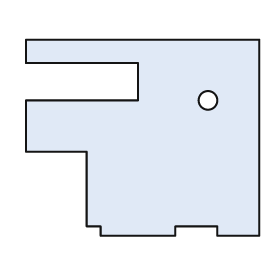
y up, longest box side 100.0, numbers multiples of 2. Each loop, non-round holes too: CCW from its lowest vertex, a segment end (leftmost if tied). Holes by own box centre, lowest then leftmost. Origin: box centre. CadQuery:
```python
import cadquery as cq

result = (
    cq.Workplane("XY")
    .moveTo(-18.0, -42.0)
    .lineTo(14.0, -42.0)
    .lineTo(14.0, -38.0)
    .lineTo(32.0, -38.0)
    .lineTo(32.0, -42.0)
    .lineTo(50.0, -42.0)
    .lineTo(50.0, 42.0)
    .lineTo(-50.0, 42.0)
    .lineTo(-50.0, 32.0)
    .lineTo(-2.0, 32.0)
    .lineTo(-2.0, 16.0)
    .lineTo(-50.0, 16.0)
    .lineTo(-50.0, -6.0)
    .lineTo(-24.0, -6.0)
    .lineTo(-24.0, -38.0)
    .lineTo(-18.0, -38.0)
    .close()
    .moveTo(28.0, 16.0)
    .circle(4.0)
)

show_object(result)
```